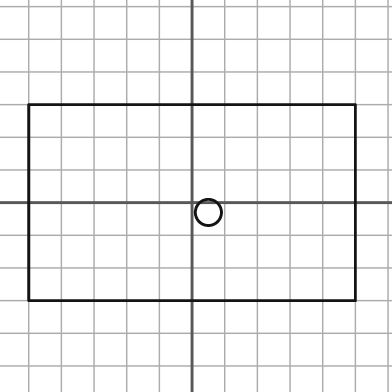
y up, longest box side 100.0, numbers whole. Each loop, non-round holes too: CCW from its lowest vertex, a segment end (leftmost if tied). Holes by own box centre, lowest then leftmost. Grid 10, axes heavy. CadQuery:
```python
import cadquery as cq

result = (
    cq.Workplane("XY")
    .moveTo(-50.0, -30.0)
    .lineTo(50.0, -30.0)
    .lineTo(50.0, 30.0)
    .lineTo(-50.0, 30.0)
    .close()
    .moveTo(5.0, -3.0)
    .circle(4.0)
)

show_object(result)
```